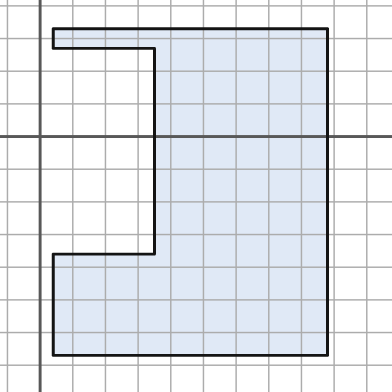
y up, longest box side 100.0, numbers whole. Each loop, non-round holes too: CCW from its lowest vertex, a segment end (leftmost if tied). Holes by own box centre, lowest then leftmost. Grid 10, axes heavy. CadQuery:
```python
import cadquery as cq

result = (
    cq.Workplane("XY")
    .moveTo(4.0, -67.0)
    .lineTo(88.0, -67.0)
    .lineTo(88.0, 33.0)
    .lineTo(4.0, 33.0)
    .lineTo(4.0, 27.0)
    .lineTo(35.0, 27.0)
    .lineTo(35.0, -36.0)
    .lineTo(4.0, -36.0)
    .close()
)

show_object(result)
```